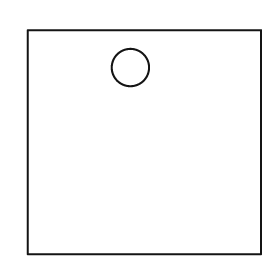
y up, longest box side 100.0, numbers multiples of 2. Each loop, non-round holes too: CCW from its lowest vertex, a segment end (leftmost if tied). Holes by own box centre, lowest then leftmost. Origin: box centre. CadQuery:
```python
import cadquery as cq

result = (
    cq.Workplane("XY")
    .moveTo(-50.0, -48.0)
    .lineTo(50.0, -48.0)
    .lineTo(50.0, 48.0)
    .lineTo(-50.0, 48.0)
    .close()
    .moveTo(-6.0, 32.0)
    .circle(8.0)
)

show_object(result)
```